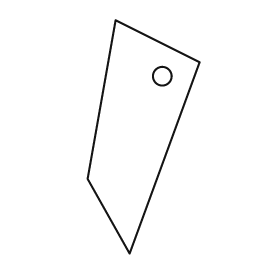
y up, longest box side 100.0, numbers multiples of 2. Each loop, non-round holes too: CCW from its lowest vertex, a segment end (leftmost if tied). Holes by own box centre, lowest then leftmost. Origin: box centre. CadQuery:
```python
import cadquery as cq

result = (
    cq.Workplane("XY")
    .moveTo(-6.0, -50.0)
    .lineTo(24.0, 32.0)
    .lineTo(-12.0, 50.0)
    .lineTo(-24.0, -18.0)
    .close()
    .moveTo(8.0, 26.0)
    .circle(4.0)
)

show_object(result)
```